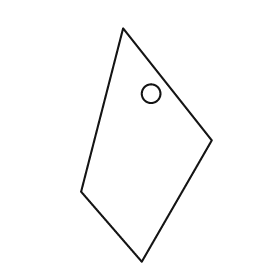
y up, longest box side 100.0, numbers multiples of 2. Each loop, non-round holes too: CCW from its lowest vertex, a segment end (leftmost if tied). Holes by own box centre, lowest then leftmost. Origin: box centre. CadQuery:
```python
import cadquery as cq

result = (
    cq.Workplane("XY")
    .moveTo(-2.0, -50.0)
    .lineTo(28.0, 2.0)
    .lineTo(-10.0, 50.0)
    .lineTo(-28.0, -20.0)
    .close()
    .moveTo(2.0, 22.0)
    .circle(4.0)
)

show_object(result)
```